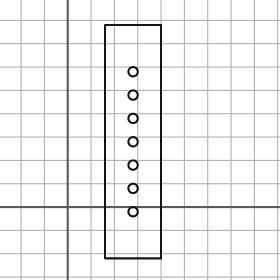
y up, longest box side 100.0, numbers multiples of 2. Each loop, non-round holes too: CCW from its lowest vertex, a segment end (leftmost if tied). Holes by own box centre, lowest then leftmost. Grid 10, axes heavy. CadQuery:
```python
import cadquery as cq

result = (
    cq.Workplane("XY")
    .moveTo(16.0, -22.0)
    .lineTo(40.0, -22.0)
    .lineTo(40.0, 78.0)
    .lineTo(16.0, 78.0)
    .close()
    .moveTo(28.0, -2.0)
    .circle(2.0)
    .moveTo(28.0, 8.0)
    .circle(2.0)
    .moveTo(28.0, 18.0)
    .circle(2.0)
    .moveTo(28.0, 28.0)
    .circle(2.0)
    .moveTo(28.0, 38.0)
    .circle(2.0)
    .moveTo(28.0, 48.0)
    .circle(2.0)
    .moveTo(28.0, 58.0)
    .circle(2.0)
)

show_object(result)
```